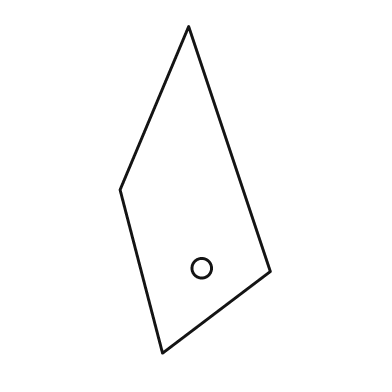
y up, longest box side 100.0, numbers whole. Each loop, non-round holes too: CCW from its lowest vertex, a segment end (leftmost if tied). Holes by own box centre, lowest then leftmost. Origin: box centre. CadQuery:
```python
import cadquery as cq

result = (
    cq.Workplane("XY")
    .moveTo(-10.0, -50.0)
    .lineTo(23.0, -25.0)
    .lineTo(-2.0, 50.0)
    .lineTo(-23.0, 0.0)
    .close()
    .moveTo(2.0, -24.0)
    .circle(3.0)
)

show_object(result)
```